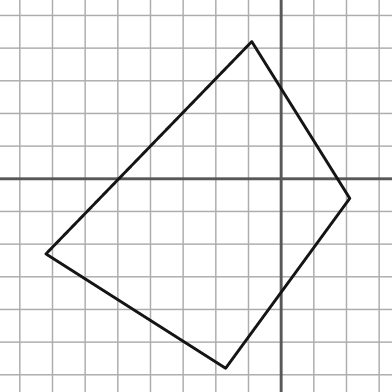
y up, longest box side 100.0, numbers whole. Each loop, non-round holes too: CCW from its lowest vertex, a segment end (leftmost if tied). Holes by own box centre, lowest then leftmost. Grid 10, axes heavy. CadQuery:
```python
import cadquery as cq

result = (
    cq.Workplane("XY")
    .moveTo(-17.0, -58.0)
    .lineTo(21.0, -6.0)
    .lineTo(-9.0, 42.0)
    .lineTo(-72.0, -23.0)
    .close()
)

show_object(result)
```